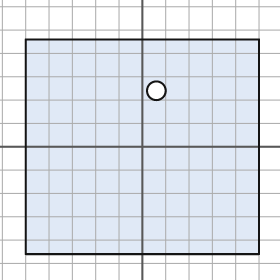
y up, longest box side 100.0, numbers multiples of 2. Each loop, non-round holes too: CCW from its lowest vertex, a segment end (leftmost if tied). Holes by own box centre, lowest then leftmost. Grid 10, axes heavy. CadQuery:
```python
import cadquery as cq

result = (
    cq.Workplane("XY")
    .moveTo(-50.0, -46.0)
    .lineTo(50.0, -46.0)
    .lineTo(50.0, 46.0)
    .lineTo(-50.0, 46.0)
    .close()
    .moveTo(6.0, 24.0)
    .circle(4.0)
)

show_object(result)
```